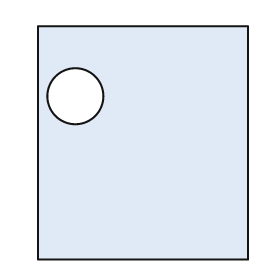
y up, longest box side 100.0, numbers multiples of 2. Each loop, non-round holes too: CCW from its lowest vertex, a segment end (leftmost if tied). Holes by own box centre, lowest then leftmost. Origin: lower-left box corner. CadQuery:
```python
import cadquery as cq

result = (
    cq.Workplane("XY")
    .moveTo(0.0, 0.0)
    .lineTo(90.0, 0.0)
    .lineTo(90.0, 100.0)
    .lineTo(0.0, 100.0)
    .close()
    .moveTo(16.0, 70.0)
    .circle(12.0)
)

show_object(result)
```